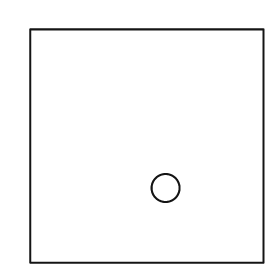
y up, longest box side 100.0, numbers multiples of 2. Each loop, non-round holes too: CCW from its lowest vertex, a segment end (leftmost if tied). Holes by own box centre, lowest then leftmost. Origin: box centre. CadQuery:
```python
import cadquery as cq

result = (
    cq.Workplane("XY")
    .moveTo(-50.0, -50.0)
    .lineTo(50.0, -50.0)
    .lineTo(50.0, 50.0)
    .lineTo(-50.0, 50.0)
    .close()
    .moveTo(8.0, -18.0)
    .circle(6.0)
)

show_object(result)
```